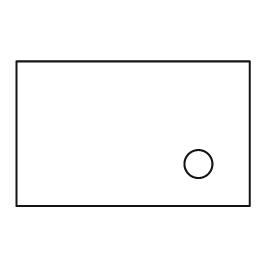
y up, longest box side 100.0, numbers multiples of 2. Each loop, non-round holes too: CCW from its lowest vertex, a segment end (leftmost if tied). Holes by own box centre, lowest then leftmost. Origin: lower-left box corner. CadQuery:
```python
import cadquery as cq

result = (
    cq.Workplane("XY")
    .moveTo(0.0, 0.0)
    .lineTo(100.0, 0.0)
    .lineTo(100.0, 62.0)
    .lineTo(0.0, 62.0)
    .close()
    .moveTo(78.0, 18.0)
    .circle(6.0)
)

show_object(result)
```